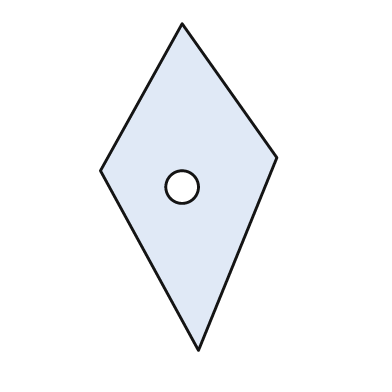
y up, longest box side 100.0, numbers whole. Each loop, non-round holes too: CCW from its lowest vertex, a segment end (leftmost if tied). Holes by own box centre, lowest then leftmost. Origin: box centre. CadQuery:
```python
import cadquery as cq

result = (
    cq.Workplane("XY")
    .moveTo(3.0, -50.0)
    .lineTo(27.0, 9.0)
    .lineTo(-2.0, 50.0)
    .lineTo(-27.0, 5.0)
    .close()
    .moveTo(-2.0, 0.0)
    .circle(5.0)
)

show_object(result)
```